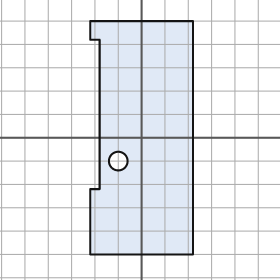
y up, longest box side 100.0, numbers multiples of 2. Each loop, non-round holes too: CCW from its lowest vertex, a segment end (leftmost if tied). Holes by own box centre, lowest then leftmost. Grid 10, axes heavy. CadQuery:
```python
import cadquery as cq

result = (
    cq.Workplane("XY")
    .moveTo(-22.0, -50.0)
    .lineTo(22.0, -50.0)
    .lineTo(22.0, 50.0)
    .lineTo(-22.0, 50.0)
    .lineTo(-22.0, 42.0)
    .lineTo(-18.0, 42.0)
    .lineTo(-18.0, -22.0)
    .lineTo(-22.0, -22.0)
    .close()
    .moveTo(-10.0, -10.0)
    .circle(4.0)
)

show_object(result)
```